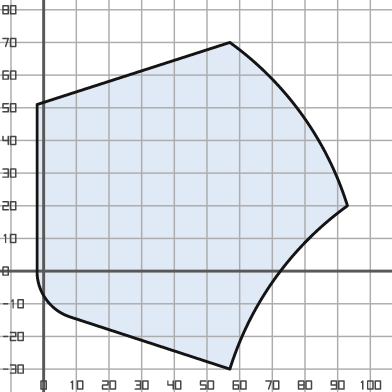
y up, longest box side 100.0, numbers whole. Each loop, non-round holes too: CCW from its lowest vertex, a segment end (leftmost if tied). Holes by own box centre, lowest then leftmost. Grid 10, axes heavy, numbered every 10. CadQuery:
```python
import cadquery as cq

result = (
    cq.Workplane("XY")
    .moveTo(57.0, -30.0)
    .threePointArc((71.0, -2.0), (93.0, 20.0))
    .threePointArc((79.0, 48.0), (57.0, 70.0))
    .lineTo(-2.0, 51.0)
    .lineTo(-2.0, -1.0)
    .threePointArc((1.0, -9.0), (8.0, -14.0))
    .close()
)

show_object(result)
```